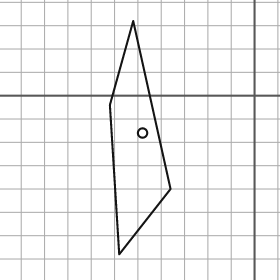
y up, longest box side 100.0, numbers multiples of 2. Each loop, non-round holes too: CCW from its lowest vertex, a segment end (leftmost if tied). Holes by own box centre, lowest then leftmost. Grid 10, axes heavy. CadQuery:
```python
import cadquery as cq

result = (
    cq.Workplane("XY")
    .moveTo(-58.0, -68.0)
    .lineTo(-36.0, -40.0)
    .lineTo(-52.0, 32.0)
    .lineTo(-62.0, -4.0)
    .close()
    .moveTo(-48.0, -16.0)
    .circle(2.0)
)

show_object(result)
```